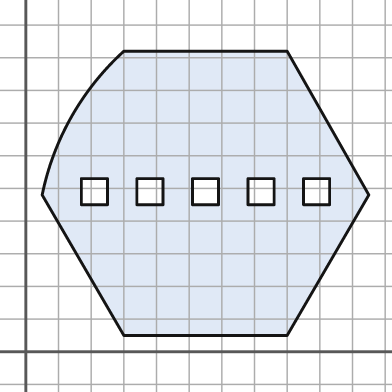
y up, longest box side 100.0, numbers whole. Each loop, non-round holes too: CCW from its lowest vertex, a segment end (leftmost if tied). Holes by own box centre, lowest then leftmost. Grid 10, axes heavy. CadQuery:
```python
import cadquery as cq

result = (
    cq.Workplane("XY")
    .moveTo(30.0, 5.0)
    .lineTo(80.0, 5.0)
    .lineTo(105.0, 48.0)
    .lineTo(80.0, 92.0)
    .lineTo(30.0, 92.0)
    .threePointArc((14.0, 72.0), (5.0, 48.0))
    .close()
    .moveTo(17.0, 45.0)
    .lineTo(25.0, 45.0)
    .lineTo(25.0, 53.0)
    .lineTo(17.0, 53.0)
    .close()
    .moveTo(34.0, 45.0)
    .lineTo(42.0, 45.0)
    .lineTo(42.0, 53.0)
    .lineTo(34.0, 53.0)
    .close()
    .moveTo(51.0, 45.0)
    .lineTo(59.0, 45.0)
    .lineTo(59.0, 53.0)
    .lineTo(51.0, 53.0)
    .close()
    .moveTo(68.0, 45.0)
    .lineTo(76.0, 45.0)
    .lineTo(76.0, 53.0)
    .lineTo(68.0, 53.0)
    .close()
    .moveTo(85.0, 45.0)
    .lineTo(93.0, 45.0)
    .lineTo(93.0, 53.0)
    .lineTo(85.0, 53.0)
    .close()
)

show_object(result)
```